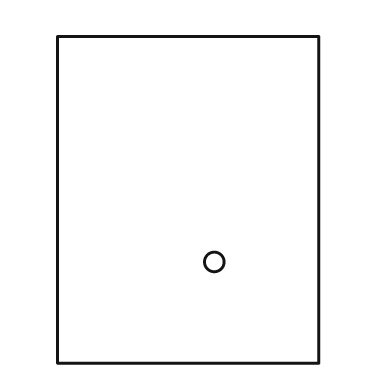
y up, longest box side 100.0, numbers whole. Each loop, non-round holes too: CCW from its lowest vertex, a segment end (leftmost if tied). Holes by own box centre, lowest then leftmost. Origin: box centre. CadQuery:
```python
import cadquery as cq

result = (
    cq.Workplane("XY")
    .moveTo(-40.0, -50.0)
    .lineTo(40.0, -50.0)
    .lineTo(40.0, 50.0)
    .lineTo(-40.0, 50.0)
    .close()
    .moveTo(8.0, -19.0)
    .circle(3.0)
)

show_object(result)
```